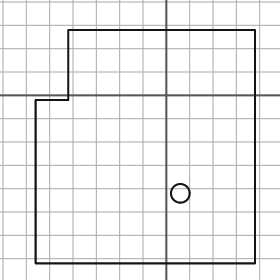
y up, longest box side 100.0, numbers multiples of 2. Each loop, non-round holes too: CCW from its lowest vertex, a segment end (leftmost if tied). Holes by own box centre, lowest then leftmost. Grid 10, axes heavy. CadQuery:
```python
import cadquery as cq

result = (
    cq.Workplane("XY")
    .moveTo(-56.0, -72.0)
    .lineTo(38.0, -72.0)
    .lineTo(38.0, 28.0)
    .lineTo(-42.0, 28.0)
    .lineTo(-42.0, -2.0)
    .lineTo(-56.0, -2.0)
    .close()
    .moveTo(6.0, -42.0)
    .circle(4.0)
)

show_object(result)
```